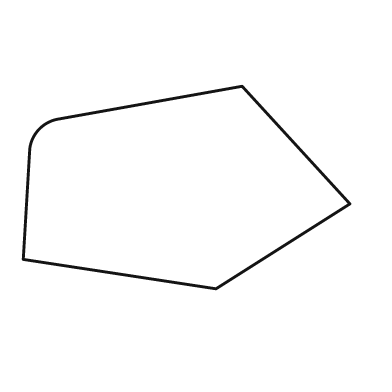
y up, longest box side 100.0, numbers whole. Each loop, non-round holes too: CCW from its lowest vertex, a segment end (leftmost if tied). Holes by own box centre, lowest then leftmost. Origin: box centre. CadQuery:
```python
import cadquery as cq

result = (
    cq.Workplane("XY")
    .moveTo(9.0, -31.0)
    .lineTo(50.0, -5.0)
    .lineTo(17.0, 31.0)
    .lineTo(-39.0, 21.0)
    .threePointArc((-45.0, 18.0), (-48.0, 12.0))
    .lineTo(-50.0, -22.0)
    .close()
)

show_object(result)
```